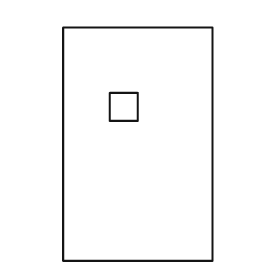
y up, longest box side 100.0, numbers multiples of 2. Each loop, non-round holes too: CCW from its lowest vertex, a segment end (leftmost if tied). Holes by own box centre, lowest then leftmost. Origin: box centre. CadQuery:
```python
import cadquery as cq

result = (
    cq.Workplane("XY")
    .moveTo(-32.0, -50.0)
    .lineTo(32.0, -50.0)
    .lineTo(32.0, 50.0)
    .lineTo(-32.0, 50.0)
    .close()
    .moveTo(-12.0, 10.0)
    .lineTo(0.0, 10.0)
    .lineTo(0.0, 22.0)
    .lineTo(-12.0, 22.0)
    .close()
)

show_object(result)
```